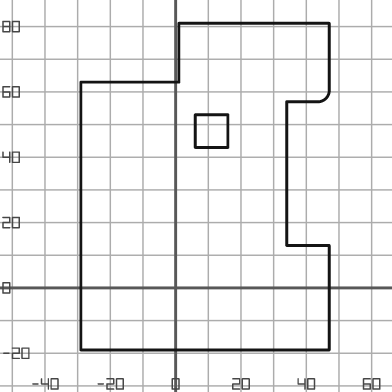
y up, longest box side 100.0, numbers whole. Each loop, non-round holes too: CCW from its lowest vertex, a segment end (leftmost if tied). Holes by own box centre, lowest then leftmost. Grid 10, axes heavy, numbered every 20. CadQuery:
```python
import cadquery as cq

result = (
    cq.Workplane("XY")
    .moveTo(-29.0, -19.0)
    .lineTo(47.0, -19.0)
    .lineTo(47.0, 13.0)
    .lineTo(34.0, 13.0)
    .lineTo(34.0, 57.0)
    .lineTo(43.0, 57.0)
    .threePointArc((46.0, 58.0), (47.0, 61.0))
    .lineTo(47.0, 81.0)
    .lineTo(1.0, 81.0)
    .lineTo(1.0, 63.0)
    .lineTo(-29.0, 63.0)
    .close()
    .moveTo(6.0, 43.0)
    .lineTo(16.0, 43.0)
    .lineTo(16.0, 53.0)
    .lineTo(6.0, 53.0)
    .close()
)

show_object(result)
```